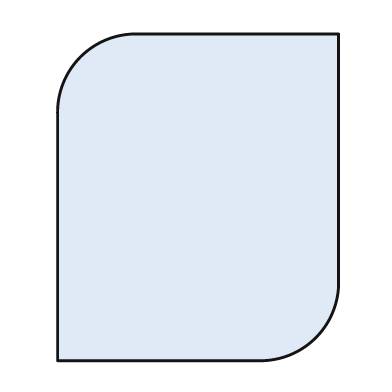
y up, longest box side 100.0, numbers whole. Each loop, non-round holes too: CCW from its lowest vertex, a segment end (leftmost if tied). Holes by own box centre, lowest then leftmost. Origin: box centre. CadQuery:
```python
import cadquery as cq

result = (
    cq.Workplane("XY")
    .moveTo(-43.0, -50.0)
    .lineTo(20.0, -50.0)
    .threePointArc((36.0, -43.0), (43.0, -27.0))
    .lineTo(43.0, 50.0)
    .lineTo(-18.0, 50.0)
    .threePointArc((-36.0, 43.0), (-43.0, 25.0))
    .close()
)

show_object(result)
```